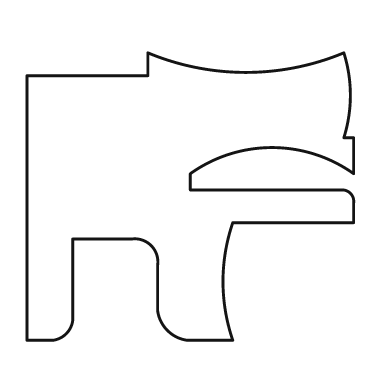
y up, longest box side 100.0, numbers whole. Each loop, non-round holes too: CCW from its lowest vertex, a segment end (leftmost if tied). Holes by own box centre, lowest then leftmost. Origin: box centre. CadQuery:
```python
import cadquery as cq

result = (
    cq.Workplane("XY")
    .moveTo(-50.0, -44.0)
    .lineTo(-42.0, -44.0)
    .threePointArc((-38.0, -42.0), (-36.0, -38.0))
    .lineTo(-36.0, -13.0)
    .lineTo(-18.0, -13.0)
    .threePointArc((-12.0, -15.0), (-10.0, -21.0))
    .lineTo(-10.0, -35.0)
    .threePointArc((-7.0, -41.0), (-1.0, -44.0))
    .lineTo(13.0, -44.0)
    .threePointArc((10.0, -26.0), (13.0, -8.0))
    .lineTo(50.0, -8.0)
    .lineTo(50.0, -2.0)
    .threePointArc((49.0, 1.0), (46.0, 2.0))
    .lineTo(0.0, 2.0)
    .lineTo(0.0, 7.0)
    .threePointArc((25.0, 15.0), (50.0, 7.0))
    .lineTo(50.0, 18.0)
    .lineTo(47.0, 18.0)
    .threePointArc((49.0, 31.0), (47.0, 44.0))
    .threePointArc((17.0, 38.0), (-13.0, 44.0))
    .lineTo(-13.0, 37.0)
    .lineTo(-50.0, 37.0)
    .close()
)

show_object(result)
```